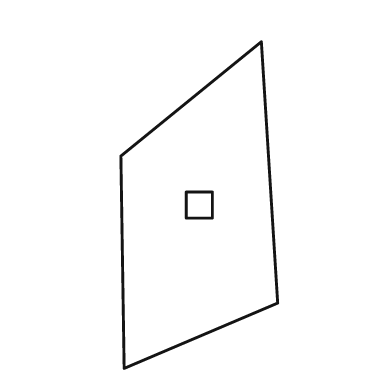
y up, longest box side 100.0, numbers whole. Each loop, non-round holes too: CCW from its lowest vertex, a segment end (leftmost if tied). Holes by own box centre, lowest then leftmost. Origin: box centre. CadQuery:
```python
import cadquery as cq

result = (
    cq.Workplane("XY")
    .moveTo(-23.0, -50.0)
    .lineTo(24.0, -30.0)
    .lineTo(19.0, 50.0)
    .lineTo(-24.0, 15.0)
    .close()
    .moveTo(-4.0, -4.0)
    .lineTo(4.0, -4.0)
    .lineTo(4.0, 4.0)
    .lineTo(-4.0, 4.0)
    .close()
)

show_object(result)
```